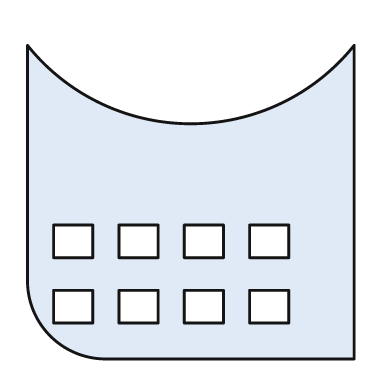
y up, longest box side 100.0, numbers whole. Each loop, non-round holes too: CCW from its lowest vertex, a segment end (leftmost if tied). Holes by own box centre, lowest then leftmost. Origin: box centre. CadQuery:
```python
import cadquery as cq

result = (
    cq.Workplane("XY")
    .moveTo(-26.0, -48.0)
    .lineTo(50.0, -48.0)
    .lineTo(50.0, 48.0)
    .threePointArc((0.0, 24.0), (-50.0, 48.0))
    .lineTo(-50.0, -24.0)
    .threePointArc((-43.0, -41.0), (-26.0, -48.0))
    .close()
    .moveTo(-42.0, -37.0)
    .lineTo(-30.0, -37.0)
    .lineTo(-30.0, -27.0)
    .lineTo(-42.0, -27.0)
    .close()
    .moveTo(-22.0, -37.0)
    .lineTo(-10.0, -37.0)
    .lineTo(-10.0, -27.0)
    .lineTo(-22.0, -27.0)
    .close()
    .moveTo(-2.0, -37.0)
    .lineTo(10.0, -37.0)
    .lineTo(10.0, -27.0)
    .lineTo(-2.0, -27.0)
    .close()
    .moveTo(18.0, -37.0)
    .lineTo(30.0, -37.0)
    .lineTo(30.0, -27.0)
    .lineTo(18.0, -27.0)
    .close()
    .moveTo(-42.0, -17.0)
    .lineTo(-30.0, -17.0)
    .lineTo(-30.0, -7.0)
    .lineTo(-42.0, -7.0)
    .close()
    .moveTo(-22.0, -17.0)
    .lineTo(-10.0, -17.0)
    .lineTo(-10.0, -7.0)
    .lineTo(-22.0, -7.0)
    .close()
    .moveTo(-2.0, -17.0)
    .lineTo(10.0, -17.0)
    .lineTo(10.0, -7.0)
    .lineTo(-2.0, -7.0)
    .close()
    .moveTo(18.0, -17.0)
    .lineTo(30.0, -17.0)
    .lineTo(30.0, -7.0)
    .lineTo(18.0, -7.0)
    .close()
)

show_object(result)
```